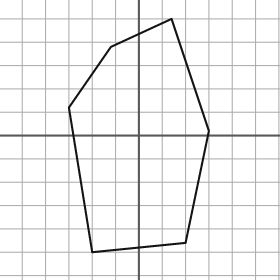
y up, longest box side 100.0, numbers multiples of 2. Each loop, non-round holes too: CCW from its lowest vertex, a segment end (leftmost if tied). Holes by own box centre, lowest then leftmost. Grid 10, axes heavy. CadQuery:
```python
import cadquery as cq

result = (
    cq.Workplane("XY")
    .moveTo(-20.0, -50.0)
    .lineTo(20.0, -46.0)
    .lineTo(30.0, 2.0)
    .lineTo(14.0, 50.0)
    .lineTo(-12.0, 38.0)
    .lineTo(-30.0, 12.0)
    .close()
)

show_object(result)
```